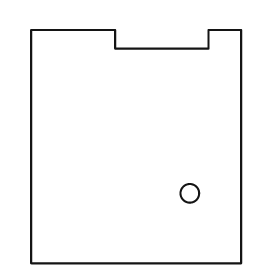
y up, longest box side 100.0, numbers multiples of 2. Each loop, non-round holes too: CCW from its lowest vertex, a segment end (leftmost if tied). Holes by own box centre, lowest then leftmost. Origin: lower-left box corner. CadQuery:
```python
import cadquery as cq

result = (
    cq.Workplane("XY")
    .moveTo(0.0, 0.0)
    .lineTo(90.0, 0.0)
    .lineTo(90.0, 100.0)
    .lineTo(76.0, 100.0)
    .lineTo(76.0, 92.0)
    .lineTo(36.0, 92.0)
    .lineTo(36.0, 100.0)
    .lineTo(0.0, 100.0)
    .close()
    .moveTo(68.0, 30.0)
    .circle(4.0)
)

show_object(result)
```